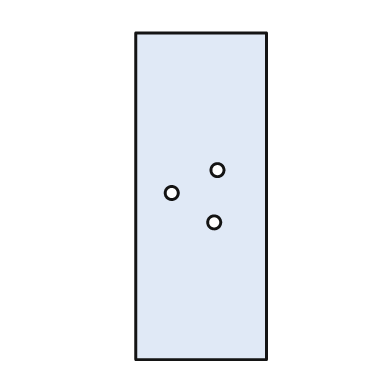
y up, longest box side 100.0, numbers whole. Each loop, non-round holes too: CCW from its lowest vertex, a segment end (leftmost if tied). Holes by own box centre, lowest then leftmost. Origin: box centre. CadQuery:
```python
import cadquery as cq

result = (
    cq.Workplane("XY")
    .moveTo(-20.0, -50.0)
    .lineTo(20.0, -50.0)
    .lineTo(20.0, 50.0)
    .lineTo(-20.0, 50.0)
    .close()
    .moveTo(4.0, -8.0)
    .circle(2.0)
    .moveTo(-9.0, 1.0)
    .circle(2.0)
    .moveTo(5.0, 8.0)
    .circle(2.0)
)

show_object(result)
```